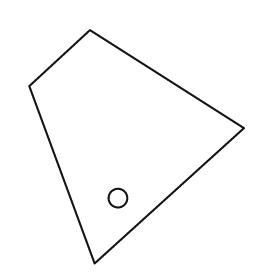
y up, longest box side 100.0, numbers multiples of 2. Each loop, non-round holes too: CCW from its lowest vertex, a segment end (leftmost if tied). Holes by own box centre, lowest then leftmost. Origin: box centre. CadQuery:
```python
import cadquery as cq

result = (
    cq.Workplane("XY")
    .moveTo(-18.0, -50.0)
    .lineTo(46.0, 8.0)
    .lineTo(-20.0, 50.0)
    .lineTo(-46.0, 26.0)
    .close()
    .moveTo(-8.0, -22.0)
    .circle(4.0)
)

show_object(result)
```